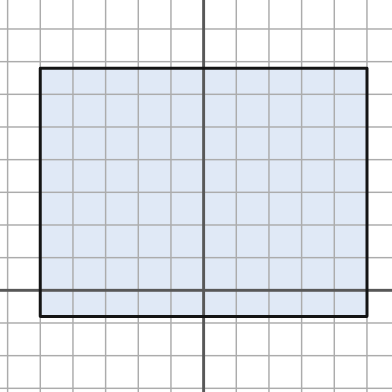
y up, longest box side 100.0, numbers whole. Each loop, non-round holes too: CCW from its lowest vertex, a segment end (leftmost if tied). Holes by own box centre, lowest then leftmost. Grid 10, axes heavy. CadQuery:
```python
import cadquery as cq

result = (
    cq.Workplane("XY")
    .moveTo(-50.0, -8.0)
    .lineTo(50.0, -8.0)
    .lineTo(50.0, 68.0)
    .lineTo(-50.0, 68.0)
    .close()
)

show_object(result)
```